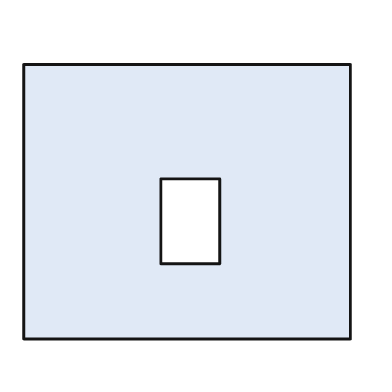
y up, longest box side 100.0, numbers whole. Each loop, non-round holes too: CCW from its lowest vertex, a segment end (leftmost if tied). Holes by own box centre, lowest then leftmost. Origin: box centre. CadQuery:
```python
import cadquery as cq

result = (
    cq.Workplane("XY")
    .moveTo(-50.0, -42.0)
    .lineTo(50.0, -42.0)
    .lineTo(50.0, 42.0)
    .lineTo(-50.0, 42.0)
    .close()
    .moveTo(-8.0, -19.0)
    .lineTo(10.0, -19.0)
    .lineTo(10.0, 7.0)
    .lineTo(-8.0, 7.0)
    .close()
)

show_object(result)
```